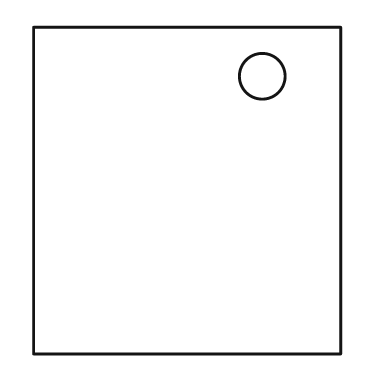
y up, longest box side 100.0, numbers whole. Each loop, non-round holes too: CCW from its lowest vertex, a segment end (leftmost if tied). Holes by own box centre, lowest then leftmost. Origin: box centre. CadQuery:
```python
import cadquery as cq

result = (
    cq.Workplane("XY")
    .moveTo(-47.0, -50.0)
    .lineTo(47.0, -50.0)
    .lineTo(47.0, 50.0)
    .lineTo(-47.0, 50.0)
    .close()
    .moveTo(23.0, 35.0)
    .circle(7.0)
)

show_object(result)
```